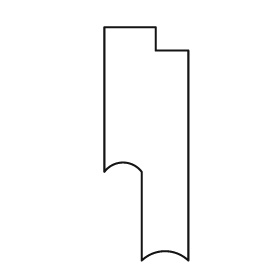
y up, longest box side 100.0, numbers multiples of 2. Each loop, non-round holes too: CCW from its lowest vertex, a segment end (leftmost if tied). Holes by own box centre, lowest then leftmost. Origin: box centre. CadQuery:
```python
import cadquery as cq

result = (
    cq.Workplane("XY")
    .moveTo(-2.0, -50.0)
    .threePointArc((8.0, -46.0), (18.0, -50.0))
    .lineTo(18.0, 40.0)
    .lineTo(4.0, 40.0)
    .lineTo(4.0, 50.0)
    .lineTo(-18.0, 50.0)
    .lineTo(-18.0, -12.0)
    .threePointArc((-10.0, -8.0), (-2.0, -12.0))
    .close()
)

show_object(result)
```